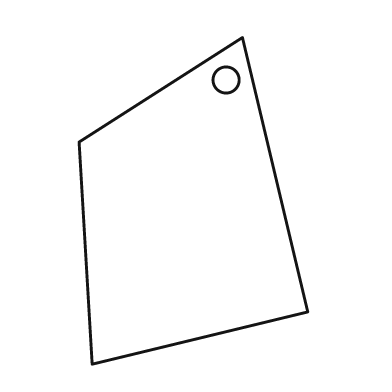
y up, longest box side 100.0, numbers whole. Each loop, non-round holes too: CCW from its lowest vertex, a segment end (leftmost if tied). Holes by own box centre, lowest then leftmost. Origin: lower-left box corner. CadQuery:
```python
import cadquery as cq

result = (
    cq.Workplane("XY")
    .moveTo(4.0, 0.0)
    .lineTo(70.0, 16.0)
    .lineTo(50.0, 100.0)
    .lineTo(0.0, 68.0)
    .close()
    .moveTo(45.0, 87.0)
    .circle(4.0)
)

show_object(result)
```